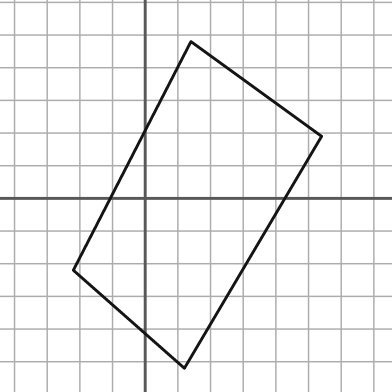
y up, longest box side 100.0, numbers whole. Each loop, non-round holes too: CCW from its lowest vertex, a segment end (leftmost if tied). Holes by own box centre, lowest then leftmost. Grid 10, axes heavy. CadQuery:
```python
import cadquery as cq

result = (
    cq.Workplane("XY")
    .moveTo(12.0, -52.0)
    .lineTo(54.0, 19.0)
    .lineTo(14.0, 48.0)
    .lineTo(-22.0, -22.0)
    .close()
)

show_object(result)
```